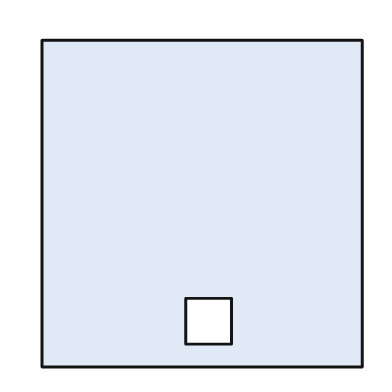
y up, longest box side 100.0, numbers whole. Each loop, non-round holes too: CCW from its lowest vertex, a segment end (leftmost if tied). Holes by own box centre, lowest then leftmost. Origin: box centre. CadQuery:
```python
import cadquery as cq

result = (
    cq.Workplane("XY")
    .moveTo(-49.0, -50.0)
    .lineTo(49.0, -50.0)
    .lineTo(49.0, 50.0)
    .lineTo(-49.0, 50.0)
    .close()
    .moveTo(-5.0, -43.0)
    .lineTo(9.0, -43.0)
    .lineTo(9.0, -29.0)
    .lineTo(-5.0, -29.0)
    .close()
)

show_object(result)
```